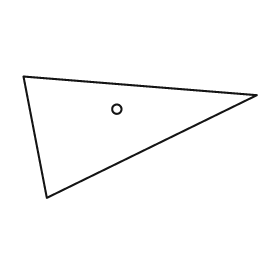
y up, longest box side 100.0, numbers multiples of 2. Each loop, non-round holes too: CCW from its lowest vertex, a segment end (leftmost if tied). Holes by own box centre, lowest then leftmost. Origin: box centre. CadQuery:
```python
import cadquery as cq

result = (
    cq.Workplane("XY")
    .moveTo(-40.0, -26.0)
    .lineTo(50.0, 18.0)
    .lineTo(-50.0, 26.0)
    .close()
    .moveTo(-10.0, 12.0)
    .circle(2.0)
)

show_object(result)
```